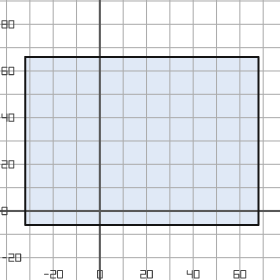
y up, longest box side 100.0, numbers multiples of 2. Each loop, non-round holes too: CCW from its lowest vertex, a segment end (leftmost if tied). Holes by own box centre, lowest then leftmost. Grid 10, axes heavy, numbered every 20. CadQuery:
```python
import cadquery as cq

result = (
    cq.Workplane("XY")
    .moveTo(-32.0, -6.0)
    .lineTo(68.0, -6.0)
    .lineTo(68.0, 66.0)
    .lineTo(-32.0, 66.0)
    .close()
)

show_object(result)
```